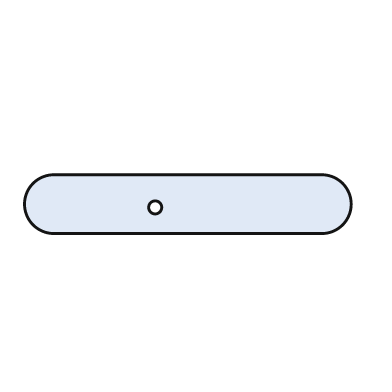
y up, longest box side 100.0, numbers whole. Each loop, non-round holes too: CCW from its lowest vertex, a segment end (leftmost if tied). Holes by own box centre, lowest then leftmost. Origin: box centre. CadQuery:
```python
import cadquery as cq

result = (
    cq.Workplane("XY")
    .moveTo(-41.0, -9.0)
    .lineTo(41.0, -9.0)
    .threePointArc((50.0, 0.0), (41.0, 9.0))
    .lineTo(-41.0, 9.0)
    .threePointArc((-50.0, 0.0), (-41.0, -9.0))
    .close()
    .moveTo(-10.0, -1.0)
    .circle(2.0)
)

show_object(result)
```